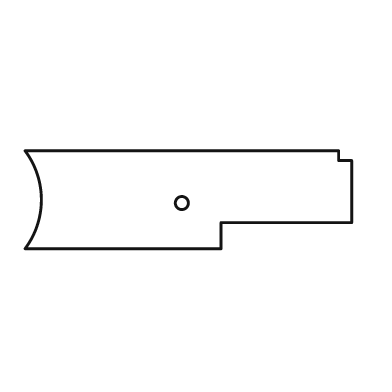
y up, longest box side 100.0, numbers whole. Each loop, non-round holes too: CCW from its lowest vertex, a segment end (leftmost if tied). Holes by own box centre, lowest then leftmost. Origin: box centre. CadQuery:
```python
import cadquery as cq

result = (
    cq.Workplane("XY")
    .moveTo(-50.0, -15.0)
    .lineTo(10.0, -15.0)
    .lineTo(10.0, -7.0)
    .lineTo(50.0, -7.0)
    .lineTo(50.0, 12.0)
    .lineTo(46.0, 12.0)
    .lineTo(46.0, 15.0)
    .lineTo(-50.0, 15.0)
    .threePointArc((-45.0, 0.0), (-50.0, -15.0))
    .close()
    .moveTo(-2.0, -1.0)
    .circle(2.0)
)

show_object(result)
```